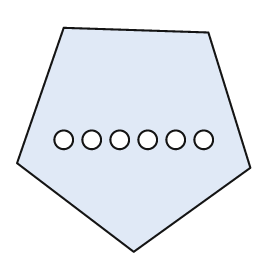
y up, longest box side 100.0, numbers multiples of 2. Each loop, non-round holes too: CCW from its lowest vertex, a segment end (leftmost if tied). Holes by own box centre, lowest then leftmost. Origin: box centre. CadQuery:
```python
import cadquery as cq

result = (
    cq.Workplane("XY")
    .moveTo(0.0, -48.0)
    .lineTo(50.0, -12.0)
    .lineTo(32.0, 46.0)
    .lineTo(-30.0, 48.0)
    .lineTo(-50.0, -10.0)
    .close()
    .moveTo(-30.0, 0.0)
    .circle(4.0)
    .moveTo(-18.0, 0.0)
    .circle(4.0)
    .moveTo(-6.0, 0.0)
    .circle(4.0)
    .moveTo(6.0, 0.0)
    .circle(4.0)
    .moveTo(18.0, 0.0)
    .circle(4.0)
    .moveTo(30.0, 0.0)
    .circle(4.0)
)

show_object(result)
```